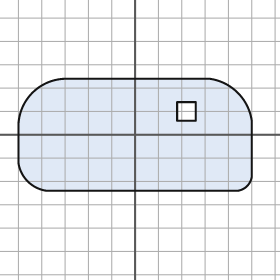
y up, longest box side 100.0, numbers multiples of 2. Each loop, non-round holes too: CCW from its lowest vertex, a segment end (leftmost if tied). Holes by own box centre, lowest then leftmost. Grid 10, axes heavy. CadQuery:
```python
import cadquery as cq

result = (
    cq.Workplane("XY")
    .moveTo(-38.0, -24.0)
    .lineTo(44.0, -24.0)
    .threePointArc((48.0, -22.0), (50.0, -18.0))
    .lineTo(50.0, 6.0)
    .threePointArc((44.0, 18.0), (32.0, 24.0))
    .lineTo(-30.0, 24.0)
    .threePointArc((-44.0, 18.0), (-50.0, 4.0))
    .lineTo(-50.0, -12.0)
    .threePointArc((-46.0, -20.0), (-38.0, -24.0))
    .close()
    .moveTo(18.0, 6.0)
    .lineTo(26.0, 6.0)
    .lineTo(26.0, 14.0)
    .lineTo(18.0, 14.0)
    .close()
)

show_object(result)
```